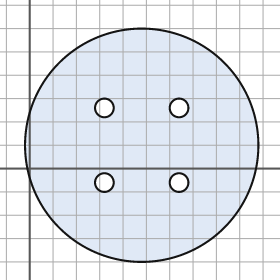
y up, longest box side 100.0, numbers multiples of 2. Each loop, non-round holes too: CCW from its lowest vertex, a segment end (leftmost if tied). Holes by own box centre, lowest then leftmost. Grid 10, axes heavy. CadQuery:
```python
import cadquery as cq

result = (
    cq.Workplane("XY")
    .moveTo(48.0, 10.0)
    .circle(50.0)
    .moveTo(32.0, -6.0)
    .circle(4.0)
    .moveTo(64.0, -6.0)
    .circle(4.0)
    .moveTo(32.0, 26.0)
    .circle(4.0)
    .moveTo(64.0, 26.0)
    .circle(4.0)
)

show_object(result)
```